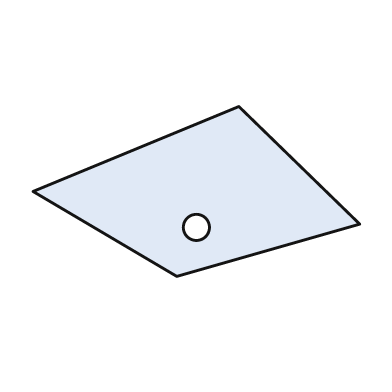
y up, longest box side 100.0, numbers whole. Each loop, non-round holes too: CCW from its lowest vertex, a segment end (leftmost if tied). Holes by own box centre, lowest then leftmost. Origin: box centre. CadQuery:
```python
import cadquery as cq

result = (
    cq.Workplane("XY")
    .moveTo(-6.0, -26.0)
    .lineTo(50.0, -10.0)
    .lineTo(13.0, 26.0)
    .lineTo(-50.0, 0.0)
    .close()
    .moveTo(0.0, -11.0)
    .circle(4.0)
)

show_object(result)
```